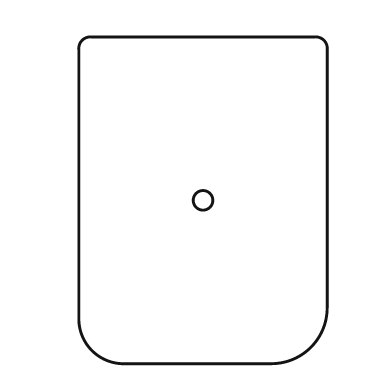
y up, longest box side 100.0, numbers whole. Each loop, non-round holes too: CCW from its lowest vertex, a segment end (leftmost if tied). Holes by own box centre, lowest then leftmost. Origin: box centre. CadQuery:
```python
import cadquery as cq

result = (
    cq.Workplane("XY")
    .moveTo(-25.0, -50.0)
    .lineTo(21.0, -50.0)
    .threePointArc((33.0, -45.0), (38.0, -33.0))
    .lineTo(38.0, 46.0)
    .threePointArc((37.0, 49.0), (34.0, 50.0))
    .lineTo(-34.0, 50.0)
    .threePointArc((-37.0, 49.0), (-38.0, 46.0))
    .lineTo(-38.0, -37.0)
    .threePointArc((-34.0, -46.0), (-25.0, -50.0))
    .close()
    .moveTo(0.0, 0.0)
    .circle(3.0)
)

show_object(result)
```